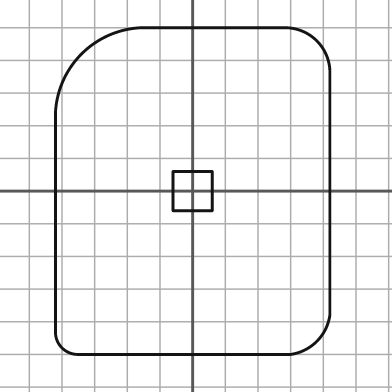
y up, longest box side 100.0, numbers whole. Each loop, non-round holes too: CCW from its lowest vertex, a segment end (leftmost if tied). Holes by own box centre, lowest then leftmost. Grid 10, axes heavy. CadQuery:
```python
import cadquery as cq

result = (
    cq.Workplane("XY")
    .moveTo(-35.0, -50.0)
    .lineTo(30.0, -50.0)
    .threePointArc((38.0, -46.0), (42.0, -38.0))
    .lineTo(42.0, 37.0)
    .threePointArc((38.0, 46.0), (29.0, 50.0))
    .lineTo(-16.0, 50.0)
    .threePointArc((-34.0, 42.0), (-42.0, 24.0))
    .lineTo(-42.0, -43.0)
    .threePointArc((-40.0, -48.0), (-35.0, -50.0))
    .close()
    .moveTo(-6.0, -6.0)
    .lineTo(6.0, -6.0)
    .lineTo(6.0, 6.0)
    .lineTo(-6.0, 6.0)
    .close()
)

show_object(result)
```